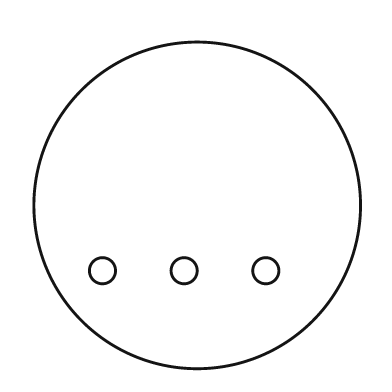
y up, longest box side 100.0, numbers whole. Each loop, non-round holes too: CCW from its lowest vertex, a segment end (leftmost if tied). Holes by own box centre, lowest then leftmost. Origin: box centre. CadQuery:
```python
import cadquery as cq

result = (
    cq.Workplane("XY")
    .moveTo(0.0, 0.0)
    .circle(50.0)
    .moveTo(-29.0, -20.0)
    .circle(4.0)
    .moveTo(-4.0, -20.0)
    .circle(4.0)
    .moveTo(21.0, -20.0)
    .circle(4.0)
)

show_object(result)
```